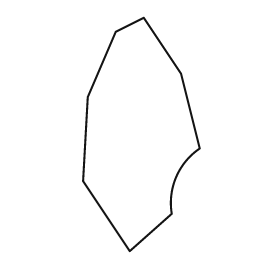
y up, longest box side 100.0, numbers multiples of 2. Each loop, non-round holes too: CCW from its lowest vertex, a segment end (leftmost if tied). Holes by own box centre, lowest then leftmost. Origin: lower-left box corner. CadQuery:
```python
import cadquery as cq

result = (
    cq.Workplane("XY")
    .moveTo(20.0, 0.0)
    .lineTo(38.0, 16.0)
    .threePointArc((40.0, 32.0), (50.0, 44.0))
    .lineTo(42.0, 76.0)
    .lineTo(26.0, 100.0)
    .lineTo(14.0, 94.0)
    .lineTo(2.0, 66.0)
    .lineTo(0.0, 30.0)
    .close()
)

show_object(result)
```